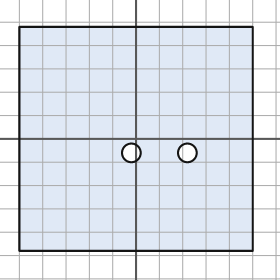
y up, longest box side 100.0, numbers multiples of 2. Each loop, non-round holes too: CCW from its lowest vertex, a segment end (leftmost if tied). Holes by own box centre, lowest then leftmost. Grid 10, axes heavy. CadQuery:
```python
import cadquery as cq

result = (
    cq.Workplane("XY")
    .moveTo(-50.0, -48.0)
    .lineTo(50.0, -48.0)
    .lineTo(50.0, 48.0)
    .lineTo(-50.0, 48.0)
    .close()
    .moveTo(-2.0, -6.0)
    .circle(4.0)
    .moveTo(22.0, -6.0)
    .circle(4.0)
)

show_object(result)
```